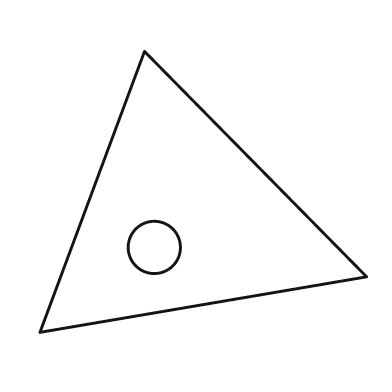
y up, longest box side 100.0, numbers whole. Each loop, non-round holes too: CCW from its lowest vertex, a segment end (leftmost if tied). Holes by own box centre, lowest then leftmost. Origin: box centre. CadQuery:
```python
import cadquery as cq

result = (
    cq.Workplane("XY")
    .moveTo(-50.0, -43.0)
    .lineTo(50.0, -26.0)
    .lineTo(-18.0, 43.0)
    .close()
    .moveTo(-15.0, -17.0)
    .circle(8.0)
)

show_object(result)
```